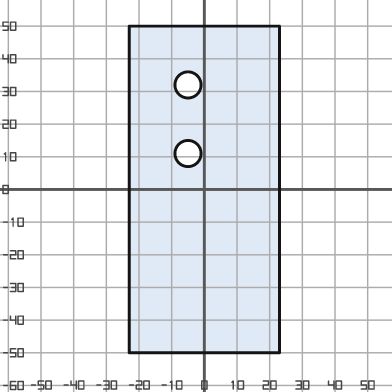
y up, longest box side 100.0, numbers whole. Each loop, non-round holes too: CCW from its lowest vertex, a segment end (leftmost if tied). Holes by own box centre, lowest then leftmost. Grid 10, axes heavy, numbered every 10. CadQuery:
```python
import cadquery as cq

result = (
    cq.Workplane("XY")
    .moveTo(-23.0, -50.0)
    .lineTo(23.0, -50.0)
    .lineTo(23.0, 50.0)
    .lineTo(-23.0, 50.0)
    .close()
    .moveTo(-5.0, 11.0)
    .circle(4.0)
    .moveTo(-5.0, 32.0)
    .circle(4.0)
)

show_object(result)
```